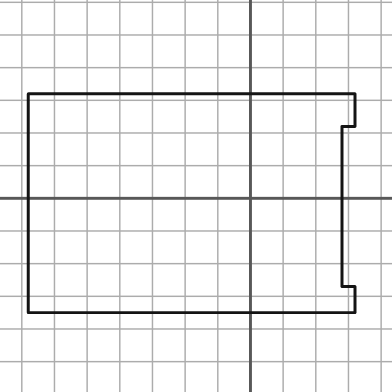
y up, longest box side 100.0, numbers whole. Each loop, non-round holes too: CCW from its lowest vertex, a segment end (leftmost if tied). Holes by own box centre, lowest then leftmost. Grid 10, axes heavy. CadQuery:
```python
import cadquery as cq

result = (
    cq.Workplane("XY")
    .moveTo(-68.0, -35.0)
    .lineTo(32.0, -35.0)
    .lineTo(32.0, -27.0)
    .lineTo(28.0, -27.0)
    .lineTo(28.0, 22.0)
    .lineTo(32.0, 22.0)
    .lineTo(32.0, 32.0)
    .lineTo(-68.0, 32.0)
    .close()
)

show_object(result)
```